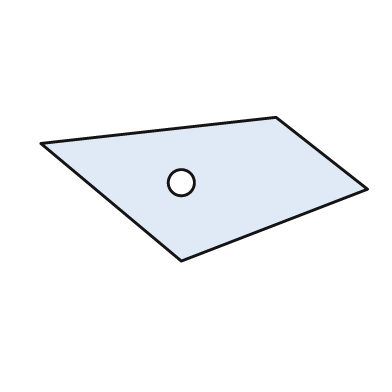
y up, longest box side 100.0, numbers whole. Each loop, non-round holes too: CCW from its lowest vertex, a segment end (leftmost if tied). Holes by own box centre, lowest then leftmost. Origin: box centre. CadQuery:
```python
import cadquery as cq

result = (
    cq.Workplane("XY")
    .moveTo(-7.0, -22.0)
    .lineTo(50.0, 0.0)
    .lineTo(22.0, 22.0)
    .lineTo(-50.0, 14.0)
    .close()
    .moveTo(-7.0, 2.0)
    .circle(4.0)
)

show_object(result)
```